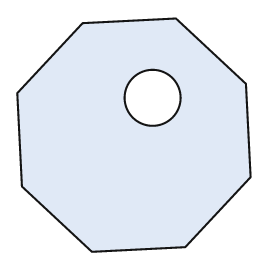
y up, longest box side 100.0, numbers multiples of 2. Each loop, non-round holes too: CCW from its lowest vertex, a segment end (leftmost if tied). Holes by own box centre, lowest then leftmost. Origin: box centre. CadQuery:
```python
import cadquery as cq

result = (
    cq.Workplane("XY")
    .moveTo(-18.0, -50.0)
    .lineTo(22.0, -48.0)
    .lineTo(50.0, -18.0)
    .lineTo(48.0, 22.0)
    .lineTo(18.0, 50.0)
    .lineTo(-22.0, 48.0)
    .lineTo(-50.0, 18.0)
    .lineTo(-48.0, -22.0)
    .close()
    .moveTo(8.0, 16.0)
    .circle(12.0)
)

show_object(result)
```